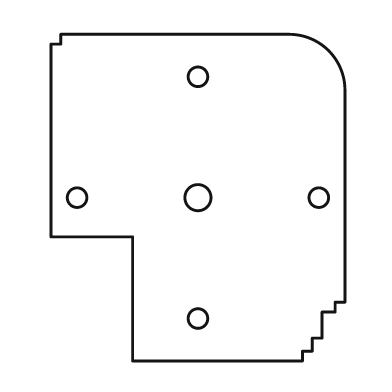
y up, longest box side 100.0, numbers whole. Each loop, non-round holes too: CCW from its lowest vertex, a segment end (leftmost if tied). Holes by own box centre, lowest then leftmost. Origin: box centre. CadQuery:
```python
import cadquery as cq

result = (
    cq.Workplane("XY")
    .moveTo(-20.0, -50.0)
    .lineTo(32.0, -50.0)
    .lineTo(32.0, -47.0)
    .lineTo(35.0, -47.0)
    .lineTo(35.0, -43.0)
    .lineTo(38.0, -43.0)
    .lineTo(38.0, -35.0)
    .lineTo(42.0, -35.0)
    .lineTo(42.0, -32.0)
    .lineTo(45.0, -32.0)
    .lineTo(45.0, 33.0)
    .threePointArc((40.0, 45.0), (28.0, 50.0))
    .lineTo(-42.0, 50.0)
    .lineTo(-42.0, 47.0)
    .lineTo(-45.0, 47.0)
    .lineTo(-45.0, -12.0)
    .lineTo(-20.0, -12.0)
    .close()
    .moveTo(0.0, -37.0)
    .circle(3.0)
    .moveTo(-37.0, 0.0)
    .circle(3.0)
    .moveTo(0.0, 0.0)
    .circle(4.0)
    .moveTo(37.0, 0.0)
    .circle(3.0)
    .moveTo(0.0, 37.0)
    .circle(3.0)
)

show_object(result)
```